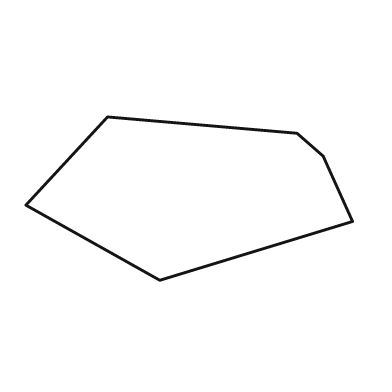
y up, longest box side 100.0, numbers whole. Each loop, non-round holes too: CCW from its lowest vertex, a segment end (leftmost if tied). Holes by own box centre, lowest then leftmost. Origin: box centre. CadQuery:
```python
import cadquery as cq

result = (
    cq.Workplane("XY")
    .moveTo(-9.0, -25.0)
    .lineTo(50.0, -7.0)
    .lineTo(41.0, 13.0)
    .lineTo(33.0, 20.0)
    .lineTo(-25.0, 25.0)
    .lineTo(-50.0, -2.0)
    .close()
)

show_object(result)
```